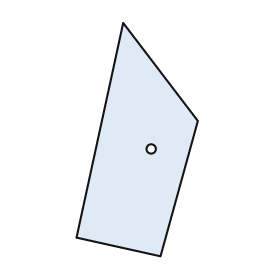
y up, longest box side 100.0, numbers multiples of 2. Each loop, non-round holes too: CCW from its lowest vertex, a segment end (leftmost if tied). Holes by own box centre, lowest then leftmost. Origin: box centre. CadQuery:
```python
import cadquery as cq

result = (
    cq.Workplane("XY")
    .moveTo(10.0, -50.0)
    .lineTo(26.0, 8.0)
    .lineTo(-6.0, 50.0)
    .lineTo(-26.0, -42.0)
    .close()
    .moveTo(6.0, -4.0)
    .circle(2.0)
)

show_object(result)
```